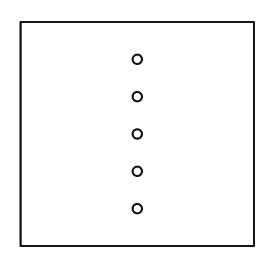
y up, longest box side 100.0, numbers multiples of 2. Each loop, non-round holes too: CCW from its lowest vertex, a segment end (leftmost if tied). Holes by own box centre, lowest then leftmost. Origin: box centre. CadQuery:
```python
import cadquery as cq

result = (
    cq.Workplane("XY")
    .moveTo(-50.0, -48.0)
    .lineTo(50.0, -48.0)
    .lineTo(50.0, 48.0)
    .lineTo(-50.0, 48.0)
    .close()
    .moveTo(0.0, -32.0)
    .circle(2.0)
    .moveTo(0.0, -16.0)
    .circle(2.0)
    .moveTo(0.0, 0.0)
    .circle(2.0)
    .moveTo(0.0, 16.0)
    .circle(2.0)
    .moveTo(0.0, 32.0)
    .circle(2.0)
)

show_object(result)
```